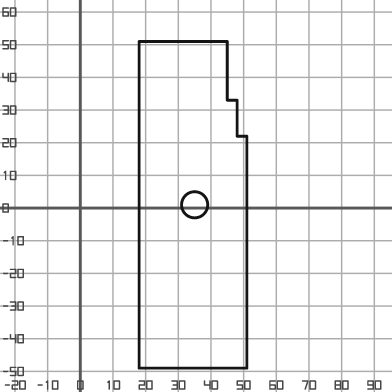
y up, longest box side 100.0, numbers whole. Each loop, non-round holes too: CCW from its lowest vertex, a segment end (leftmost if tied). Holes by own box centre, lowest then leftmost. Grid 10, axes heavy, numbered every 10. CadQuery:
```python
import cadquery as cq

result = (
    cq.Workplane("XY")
    .moveTo(18.0, -49.0)
    .lineTo(51.0, -49.0)
    .lineTo(51.0, 22.0)
    .lineTo(48.0, 22.0)
    .lineTo(48.0, 33.0)
    .lineTo(45.0, 33.0)
    .lineTo(45.0, 51.0)
    .lineTo(18.0, 51.0)
    .close()
    .moveTo(35.0, 1.0)
    .circle(4.0)
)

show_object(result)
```